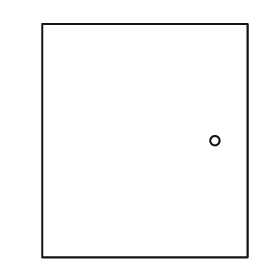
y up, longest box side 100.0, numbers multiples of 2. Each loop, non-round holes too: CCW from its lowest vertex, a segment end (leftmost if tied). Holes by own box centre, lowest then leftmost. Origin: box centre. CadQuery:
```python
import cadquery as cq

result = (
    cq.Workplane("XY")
    .moveTo(-44.0, -50.0)
    .lineTo(44.0, -50.0)
    .lineTo(44.0, 50.0)
    .lineTo(-44.0, 50.0)
    .close()
    .moveTo(30.0, 0.0)
    .circle(2.0)
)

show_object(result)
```